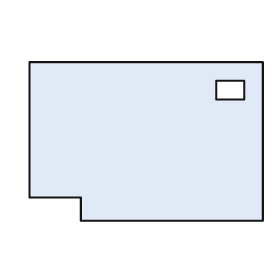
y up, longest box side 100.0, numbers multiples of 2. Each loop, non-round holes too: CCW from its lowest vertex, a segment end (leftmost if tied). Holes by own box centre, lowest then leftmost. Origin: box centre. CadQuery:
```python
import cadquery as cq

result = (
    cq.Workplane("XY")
    .moveTo(-28.0, -34.0)
    .lineTo(50.0, -34.0)
    .lineTo(50.0, 34.0)
    .lineTo(-50.0, 34.0)
    .lineTo(-50.0, -24.0)
    .lineTo(-28.0, -24.0)
    .close()
    .moveTo(30.0, 18.0)
    .lineTo(42.0, 18.0)
    .lineTo(42.0, 26.0)
    .lineTo(30.0, 26.0)
    .close()
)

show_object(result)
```